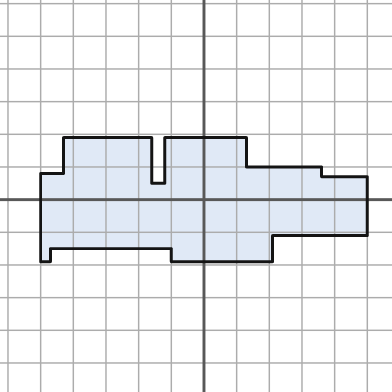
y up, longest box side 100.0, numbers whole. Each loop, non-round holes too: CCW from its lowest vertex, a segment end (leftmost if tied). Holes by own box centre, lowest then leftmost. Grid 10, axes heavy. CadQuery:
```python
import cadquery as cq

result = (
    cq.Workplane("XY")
    .moveTo(-50.0, -19.0)
    .lineTo(-47.0, -19.0)
    .lineTo(-47.0, -15.0)
    .lineTo(-10.0, -15.0)
    .lineTo(-10.0, -19.0)
    .lineTo(21.0, -19.0)
    .lineTo(21.0, -11.0)
    .lineTo(50.0, -11.0)
    .lineTo(50.0, 7.0)
    .lineTo(36.0, 7.0)
    .lineTo(36.0, 10.0)
    .lineTo(13.0, 10.0)
    .lineTo(13.0, 19.0)
    .lineTo(-12.0, 19.0)
    .lineTo(-12.0, 5.0)
    .lineTo(-16.0, 5.0)
    .lineTo(-16.0, 19.0)
    .lineTo(-43.0, 19.0)
    .lineTo(-43.0, 8.0)
    .lineTo(-50.0, 8.0)
    .close()
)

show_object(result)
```